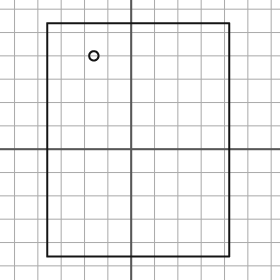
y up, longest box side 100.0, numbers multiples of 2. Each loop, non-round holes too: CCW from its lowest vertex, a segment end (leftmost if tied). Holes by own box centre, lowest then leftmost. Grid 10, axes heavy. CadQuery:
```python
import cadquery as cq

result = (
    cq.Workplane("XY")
    .moveTo(-36.0, -46.0)
    .lineTo(42.0, -46.0)
    .lineTo(42.0, 54.0)
    .lineTo(-36.0, 54.0)
    .close()
    .moveTo(-16.0, 40.0)
    .circle(2.0)
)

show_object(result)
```